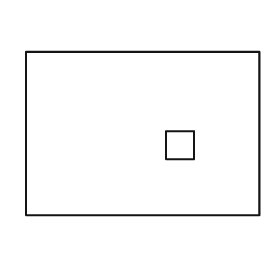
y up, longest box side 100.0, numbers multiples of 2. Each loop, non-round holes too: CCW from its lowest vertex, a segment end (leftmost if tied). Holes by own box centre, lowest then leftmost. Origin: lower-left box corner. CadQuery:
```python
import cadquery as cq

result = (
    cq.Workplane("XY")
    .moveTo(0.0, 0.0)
    .lineTo(100.0, 0.0)
    .lineTo(100.0, 70.0)
    .lineTo(0.0, 70.0)
    .close()
    .moveTo(60.0, 24.0)
    .lineTo(72.0, 24.0)
    .lineTo(72.0, 36.0)
    .lineTo(60.0, 36.0)
    .close()
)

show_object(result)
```